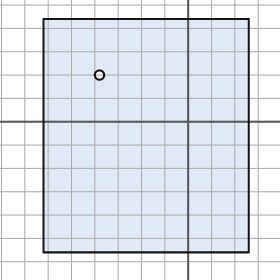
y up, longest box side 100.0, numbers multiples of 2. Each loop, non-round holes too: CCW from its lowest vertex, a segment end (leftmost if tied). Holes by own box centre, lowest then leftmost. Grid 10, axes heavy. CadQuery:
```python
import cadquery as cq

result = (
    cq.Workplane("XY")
    .moveTo(-62.0, -56.0)
    .lineTo(26.0, -56.0)
    .lineTo(26.0, 44.0)
    .lineTo(-62.0, 44.0)
    .close()
    .moveTo(-38.0, 20.0)
    .circle(2.0)
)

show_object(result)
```